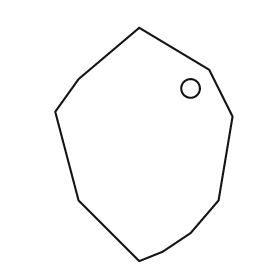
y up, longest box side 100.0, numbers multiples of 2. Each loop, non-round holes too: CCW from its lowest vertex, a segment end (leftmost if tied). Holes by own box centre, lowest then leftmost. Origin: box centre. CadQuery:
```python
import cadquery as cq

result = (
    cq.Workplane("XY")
    .moveTo(-2.0, -50.0)
    .lineTo(8.0, -46.0)
    .lineTo(20.0, -38.0)
    .lineTo(32.0, -24.0)
    .lineTo(38.0, 12.0)
    .lineTo(28.0, 32.0)
    .lineTo(-2.0, 50.0)
    .lineTo(-28.0, 28.0)
    .lineTo(-38.0, 14.0)
    .lineTo(-28.0, -24.0)
    .close()
    .moveTo(20.0, 24.0)
    .circle(4.0)
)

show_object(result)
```